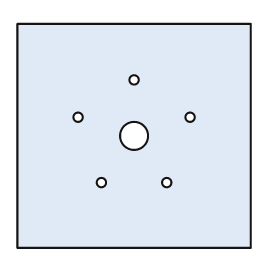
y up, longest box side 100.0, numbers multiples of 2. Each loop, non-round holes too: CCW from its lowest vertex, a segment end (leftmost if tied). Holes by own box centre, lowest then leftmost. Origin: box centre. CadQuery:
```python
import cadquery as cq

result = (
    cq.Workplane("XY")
    .moveTo(-50.0, -48.0)
    .lineTo(50.0, -48.0)
    .lineTo(50.0, 48.0)
    .lineTo(-50.0, 48.0)
    .close()
    .moveTo(-14.0, -20.0)
    .circle(2.0)
    .moveTo(14.0, -20.0)
    .circle(2.0)
    .moveTo(0.0, 0.0)
    .circle(6.0)
    .moveTo(-24.0, 8.0)
    .circle(2.0)
    .moveTo(24.0, 8.0)
    .circle(2.0)
    .moveTo(0.0, 24.0)
    .circle(2.0)
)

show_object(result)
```